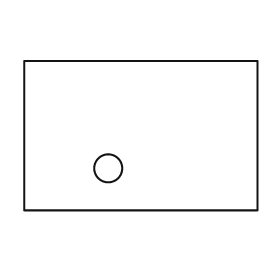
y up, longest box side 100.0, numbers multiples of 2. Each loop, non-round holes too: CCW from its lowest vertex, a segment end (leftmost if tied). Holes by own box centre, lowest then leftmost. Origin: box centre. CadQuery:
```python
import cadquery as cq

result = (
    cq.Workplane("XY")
    .moveTo(-50.0, -32.0)
    .lineTo(50.0, -32.0)
    .lineTo(50.0, 32.0)
    .lineTo(-50.0, 32.0)
    .close()
    .moveTo(-14.0, -14.0)
    .circle(6.0)
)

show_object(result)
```